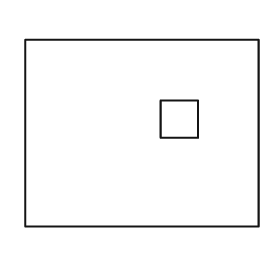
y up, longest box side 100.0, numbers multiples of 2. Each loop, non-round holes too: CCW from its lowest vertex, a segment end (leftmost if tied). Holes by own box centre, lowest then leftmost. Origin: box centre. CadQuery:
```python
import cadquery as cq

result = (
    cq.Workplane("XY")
    .moveTo(-50.0, -40.0)
    .lineTo(50.0, -40.0)
    .lineTo(50.0, 40.0)
    .lineTo(-50.0, 40.0)
    .close()
    .moveTo(8.0, -2.0)
    .lineTo(24.0, -2.0)
    .lineTo(24.0, 14.0)
    .lineTo(8.0, 14.0)
    .close()
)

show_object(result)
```